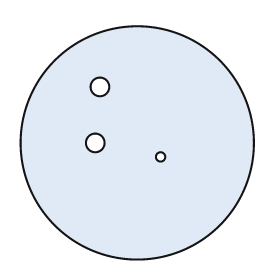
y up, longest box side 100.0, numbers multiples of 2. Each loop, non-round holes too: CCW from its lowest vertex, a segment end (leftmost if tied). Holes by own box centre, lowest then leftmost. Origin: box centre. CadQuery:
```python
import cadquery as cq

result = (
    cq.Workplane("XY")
    .moveTo(0.0, 0.0)
    .circle(50.0)
    .moveTo(10.0, -6.0)
    .circle(2.0)
    .moveTo(-18.0, 0.0)
    .circle(4.0)
    .moveTo(-16.0, 24.0)
    .circle(4.0)
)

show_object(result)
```